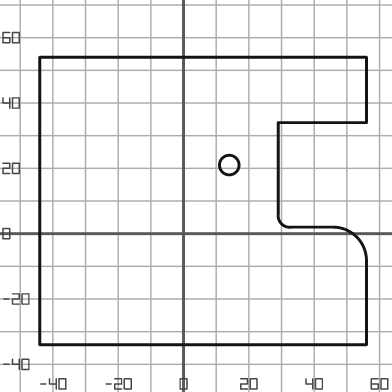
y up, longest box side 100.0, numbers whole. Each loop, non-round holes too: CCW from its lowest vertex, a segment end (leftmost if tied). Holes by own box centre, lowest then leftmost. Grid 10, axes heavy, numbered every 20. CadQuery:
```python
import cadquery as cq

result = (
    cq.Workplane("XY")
    .moveTo(-44.0, -34.0)
    .lineTo(56.0, -34.0)
    .lineTo(56.0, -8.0)
    .threePointArc((53.0, -1.0), (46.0, 2.0))
    .lineTo(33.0, 2.0)
    .threePointArc((30.0, 3.0), (29.0, 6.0))
    .lineTo(29.0, 34.0)
    .lineTo(56.0, 34.0)
    .lineTo(56.0, 54.0)
    .lineTo(-44.0, 54.0)
    .close()
    .moveTo(14.0, 21.0)
    .circle(3.0)
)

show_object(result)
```